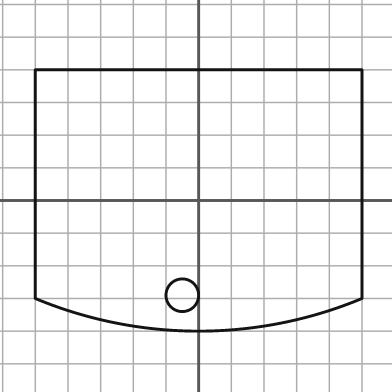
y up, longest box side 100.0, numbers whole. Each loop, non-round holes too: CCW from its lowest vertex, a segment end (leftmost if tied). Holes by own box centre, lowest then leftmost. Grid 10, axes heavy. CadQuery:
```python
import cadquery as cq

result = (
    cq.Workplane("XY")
    .moveTo(-50.0, -30.0)
    .threePointArc((0.0, -40.0), (50.0, -30.0))
    .lineTo(50.0, 40.0)
    .lineTo(-50.0, 40.0)
    .close()
    .moveTo(-5.0, -29.0)
    .circle(5.0)
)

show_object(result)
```